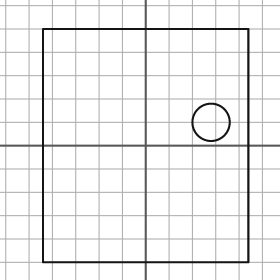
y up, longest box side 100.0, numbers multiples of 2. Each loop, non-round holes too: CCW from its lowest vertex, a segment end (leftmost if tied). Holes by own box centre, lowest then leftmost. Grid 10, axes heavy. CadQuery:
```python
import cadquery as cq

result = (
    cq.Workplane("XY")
    .moveTo(-44.0, -50.0)
    .lineTo(44.0, -50.0)
    .lineTo(44.0, 50.0)
    .lineTo(-44.0, 50.0)
    .close()
    .moveTo(28.0, 10.0)
    .circle(8.0)
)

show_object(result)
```